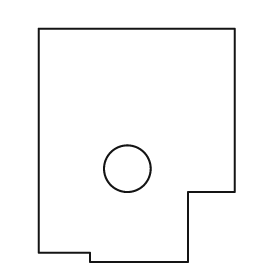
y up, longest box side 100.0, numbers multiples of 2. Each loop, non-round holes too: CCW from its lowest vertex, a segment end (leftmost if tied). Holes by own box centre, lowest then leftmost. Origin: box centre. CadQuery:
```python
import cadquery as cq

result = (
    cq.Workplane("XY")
    .moveTo(-20.0, -50.0)
    .lineTo(22.0, -50.0)
    .lineTo(22.0, -20.0)
    .lineTo(42.0, -20.0)
    .lineTo(42.0, 50.0)
    .lineTo(-42.0, 50.0)
    .lineTo(-42.0, -46.0)
    .lineTo(-20.0, -46.0)
    .close()
    .moveTo(-4.0, -10.0)
    .circle(10.0)
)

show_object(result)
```